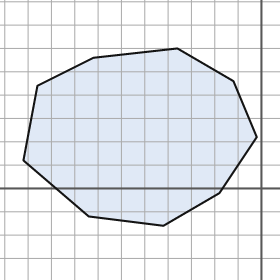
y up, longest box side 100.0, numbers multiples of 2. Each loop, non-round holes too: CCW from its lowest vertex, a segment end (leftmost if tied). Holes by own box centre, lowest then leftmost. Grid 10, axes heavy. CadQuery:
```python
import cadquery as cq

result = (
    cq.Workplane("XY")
    .moveTo(-42.0, -16.0)
    .lineTo(-18.0, -2.0)
    .lineTo(-2.0, 22.0)
    .lineTo(-12.0, 46.0)
    .lineTo(-36.0, 60.0)
    .lineTo(-72.0, 56.0)
    .lineTo(-96.0, 44.0)
    .lineTo(-102.0, 12.0)
    .lineTo(-74.0, -12.0)
    .close()
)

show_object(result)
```